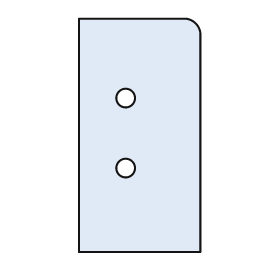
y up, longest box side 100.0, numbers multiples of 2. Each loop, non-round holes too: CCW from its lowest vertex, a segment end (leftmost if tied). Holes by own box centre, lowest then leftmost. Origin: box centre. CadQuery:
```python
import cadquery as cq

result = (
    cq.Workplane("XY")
    .moveTo(-26.0, -50.0)
    .lineTo(26.0, -50.0)
    .lineTo(26.0, 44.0)
    .threePointArc((24.0, 48.0), (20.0, 50.0))
    .lineTo(-26.0, 50.0)
    .close()
    .moveTo(-6.0, -14.0)
    .circle(4.0)
    .moveTo(-6.0, 16.0)
    .circle(4.0)
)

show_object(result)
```